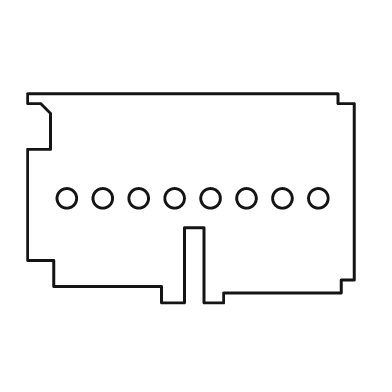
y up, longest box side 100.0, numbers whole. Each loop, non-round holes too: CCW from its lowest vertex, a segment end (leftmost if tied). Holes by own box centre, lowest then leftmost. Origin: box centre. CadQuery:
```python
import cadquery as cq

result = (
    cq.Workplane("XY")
    .moveTo(-9.0, -32.0)
    .lineTo(-2.0, -32.0)
    .lineTo(-2.0, -9.0)
    .lineTo(4.0, -9.0)
    .lineTo(4.0, -32.0)
    .lineTo(10.0, -32.0)
    .lineTo(10.0, -29.0)
    .lineTo(46.0, -29.0)
    .lineTo(46.0, -25.0)
    .lineTo(50.0, -25.0)
    .lineTo(50.0, 29.0)
    .lineTo(45.0, 29.0)
    .lineTo(45.0, 32.0)
    .lineTo(-50.0, 32.0)
    .lineTo(-50.0, 29.0)
    .lineTo(-46.0, 29.0)
    .lineTo(-43.0, 26.0)
    .lineTo(-43.0, 15.0)
    .lineTo(-50.0, 15.0)
    .lineTo(-50.0, -19.0)
    .lineTo(-42.0, -19.0)
    .lineTo(-42.0, -27.0)
    .lineTo(-9.0, -27.0)
    .close()
    .moveTo(-38.0, 0.0)
    .circle(3.0)
    .moveTo(-27.0, 0.0)
    .circle(3.0)
    .moveTo(-16.0, 0.0)
    .circle(3.0)
    .moveTo(-5.0, 0.0)
    .circle(3.0)
    .moveTo(6.0, 0.0)
    .circle(3.0)
    .moveTo(17.0, 0.0)
    .circle(3.0)
    .moveTo(28.0, 0.0)
    .circle(3.0)
    .moveTo(39.0, 0.0)
    .circle(3.0)
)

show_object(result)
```